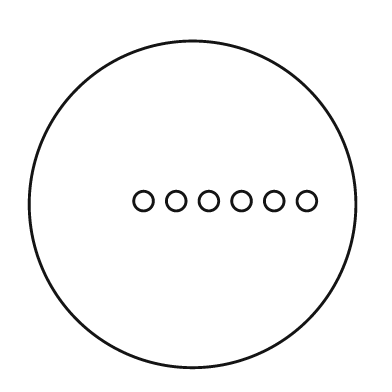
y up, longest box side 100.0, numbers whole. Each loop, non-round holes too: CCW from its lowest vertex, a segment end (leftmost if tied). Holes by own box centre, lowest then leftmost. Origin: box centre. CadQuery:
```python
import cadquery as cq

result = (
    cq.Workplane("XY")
    .moveTo(0.0, 0.0)
    .circle(50.0)
    .moveTo(-15.0, 1.0)
    .circle(3.0)
    .moveTo(-5.0, 1.0)
    .circle(3.0)
    .moveTo(5.0, 1.0)
    .circle(3.0)
    .moveTo(15.0, 1.0)
    .circle(3.0)
    .moveTo(25.0, 1.0)
    .circle(3.0)
    .moveTo(35.0, 1.0)
    .circle(3.0)
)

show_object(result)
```